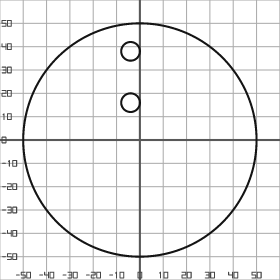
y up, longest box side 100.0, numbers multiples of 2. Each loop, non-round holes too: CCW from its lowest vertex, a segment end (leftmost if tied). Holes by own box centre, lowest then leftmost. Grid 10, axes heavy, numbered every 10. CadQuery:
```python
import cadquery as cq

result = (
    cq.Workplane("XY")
    .moveTo(0.0, 0.0)
    .circle(50.0)
    .moveTo(-4.0, 16.0)
    .circle(4.0)
    .moveTo(-4.0, 38.0)
    .circle(4.0)
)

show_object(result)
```